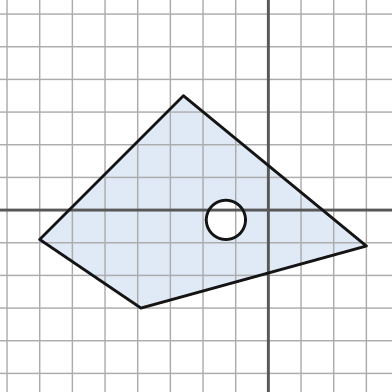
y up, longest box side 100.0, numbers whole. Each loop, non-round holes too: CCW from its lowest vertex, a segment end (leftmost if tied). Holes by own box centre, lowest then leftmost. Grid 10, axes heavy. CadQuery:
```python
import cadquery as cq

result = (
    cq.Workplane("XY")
    .moveTo(-39.0, -30.0)
    .lineTo(30.0, -11.0)
    .lineTo(-26.0, 35.0)
    .lineTo(-70.0, -9.0)
    .close()
    .moveTo(-13.0, -3.0)
    .circle(6.0)
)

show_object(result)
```